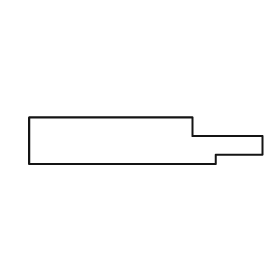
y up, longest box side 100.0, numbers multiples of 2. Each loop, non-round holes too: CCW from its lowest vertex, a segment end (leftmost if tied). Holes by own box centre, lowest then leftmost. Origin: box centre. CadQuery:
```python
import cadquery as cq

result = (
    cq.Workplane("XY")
    .moveTo(-50.0, -10.0)
    .lineTo(30.0, -10.0)
    .lineTo(30.0, -6.0)
    .lineTo(50.0, -6.0)
    .lineTo(50.0, 2.0)
    .lineTo(20.0, 2.0)
    .lineTo(20.0, 10.0)
    .lineTo(-50.0, 10.0)
    .close()
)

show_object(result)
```